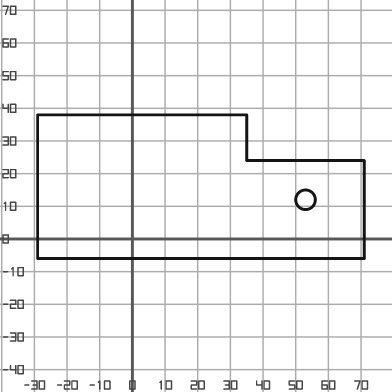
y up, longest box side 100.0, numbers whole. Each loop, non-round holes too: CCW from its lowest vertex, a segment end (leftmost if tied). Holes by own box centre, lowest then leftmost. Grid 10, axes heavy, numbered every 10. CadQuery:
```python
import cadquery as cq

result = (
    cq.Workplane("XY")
    .moveTo(-29.0, -6.0)
    .lineTo(71.0, -6.0)
    .lineTo(71.0, 24.0)
    .lineTo(35.0, 24.0)
    .lineTo(35.0, 38.0)
    .lineTo(-29.0, 38.0)
    .close()
    .moveTo(53.0, 12.0)
    .circle(3.0)
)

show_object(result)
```